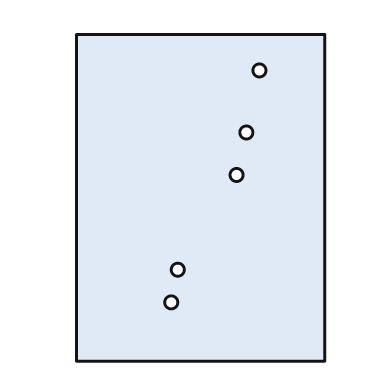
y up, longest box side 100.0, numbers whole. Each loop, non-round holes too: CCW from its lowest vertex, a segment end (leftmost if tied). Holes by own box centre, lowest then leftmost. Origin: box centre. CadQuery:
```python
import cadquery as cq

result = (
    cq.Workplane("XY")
    .moveTo(-38.0, -50.0)
    .lineTo(38.0, -50.0)
    .lineTo(38.0, 50.0)
    .lineTo(-38.0, 50.0)
    .close()
    .moveTo(-9.0, -32.0)
    .circle(2.0)
    .moveTo(-7.0, -22.0)
    .circle(2.0)
    .moveTo(11.0, 7.0)
    .circle(2.0)
    .moveTo(14.0, 20.0)
    .circle(2.0)
    .moveTo(18.0, 39.0)
    .circle(2.0)
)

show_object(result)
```